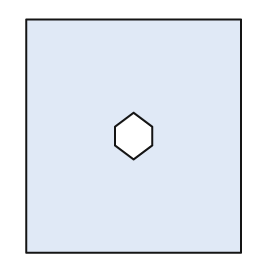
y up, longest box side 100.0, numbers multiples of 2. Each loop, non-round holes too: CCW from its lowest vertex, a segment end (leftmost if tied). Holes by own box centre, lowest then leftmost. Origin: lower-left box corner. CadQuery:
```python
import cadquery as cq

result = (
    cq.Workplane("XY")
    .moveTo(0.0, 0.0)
    .lineTo(92.0, 0.0)
    .lineTo(92.0, 100.0)
    .lineTo(0.0, 100.0)
    .close()
    .moveTo(46.0, 40.0)
    .lineTo(54.0, 46.0)
    .lineTo(54.0, 54.0)
    .lineTo(46.0, 60.0)
    .lineTo(38.0, 54.0)
    .lineTo(38.0, 46.0)
    .close()
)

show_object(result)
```